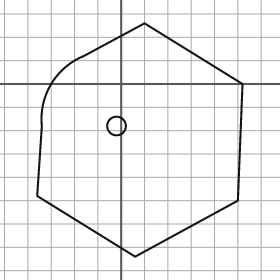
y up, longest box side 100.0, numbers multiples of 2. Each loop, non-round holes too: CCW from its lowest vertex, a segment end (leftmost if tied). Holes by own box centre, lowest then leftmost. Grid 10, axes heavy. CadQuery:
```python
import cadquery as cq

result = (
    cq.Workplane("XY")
    .moveTo(6.0, -74.0)
    .lineTo(50.0, -50.0)
    .lineTo(52.0, 0.0)
    .lineTo(10.0, 26.0)
    .lineTo(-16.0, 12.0)
    .threePointArc((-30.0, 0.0), (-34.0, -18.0))
    .lineTo(-36.0, -48.0)
    .close()
    .moveTo(-2.0, -18.0)
    .circle(4.0)
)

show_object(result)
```